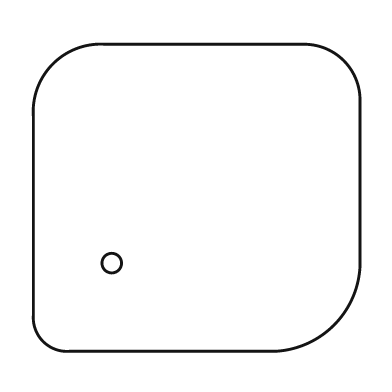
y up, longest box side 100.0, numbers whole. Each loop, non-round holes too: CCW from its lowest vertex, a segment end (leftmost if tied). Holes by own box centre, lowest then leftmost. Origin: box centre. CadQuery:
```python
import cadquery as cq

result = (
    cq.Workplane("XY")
    .moveTo(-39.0, -47.0)
    .lineTo(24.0, -47.0)
    .threePointArc((42.0, -39.0), (50.0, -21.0))
    .lineTo(50.0, 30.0)
    .threePointArc((45.0, 42.0), (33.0, 47.0))
    .lineTo(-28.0, 47.0)
    .threePointArc((-44.0, 41.0), (-50.0, 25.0))
    .lineTo(-50.0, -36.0)
    .threePointArc((-47.0, -44.0), (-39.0, -47.0))
    .close()
    .moveTo(-26.0, -20.0)
    .circle(3.0)
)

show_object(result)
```